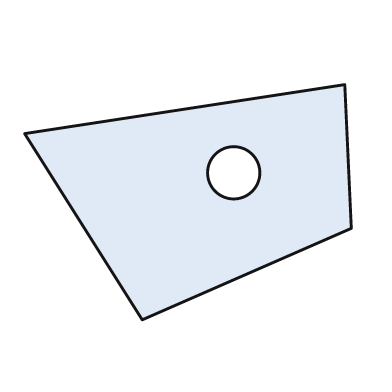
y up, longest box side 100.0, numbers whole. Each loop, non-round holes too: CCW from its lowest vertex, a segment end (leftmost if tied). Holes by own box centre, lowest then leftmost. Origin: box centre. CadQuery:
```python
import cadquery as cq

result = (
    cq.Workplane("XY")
    .moveTo(-14.0, -36.0)
    .lineTo(50.0, -8.0)
    .lineTo(48.0, 36.0)
    .lineTo(-50.0, 21.0)
    .close()
    .moveTo(14.0, 9.0)
    .circle(8.0)
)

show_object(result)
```